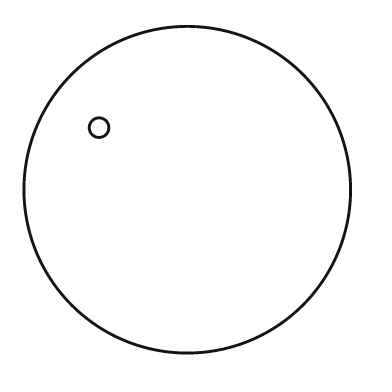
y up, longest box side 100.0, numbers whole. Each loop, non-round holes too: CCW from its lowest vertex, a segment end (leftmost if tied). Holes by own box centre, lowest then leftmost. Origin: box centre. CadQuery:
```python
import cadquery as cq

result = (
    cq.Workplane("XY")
    .moveTo(0.0, 0.0)
    .circle(50.0)
    .moveTo(-27.0, 19.0)
    .circle(3.0)
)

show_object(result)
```